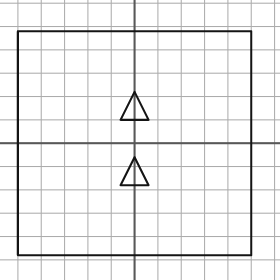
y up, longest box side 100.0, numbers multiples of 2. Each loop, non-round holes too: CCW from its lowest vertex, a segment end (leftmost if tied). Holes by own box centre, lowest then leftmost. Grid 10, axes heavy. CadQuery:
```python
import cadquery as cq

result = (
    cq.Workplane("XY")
    .moveTo(-50.0, -48.0)
    .lineTo(50.0, -48.0)
    .lineTo(50.0, 48.0)
    .lineTo(-50.0, 48.0)
    .close()
    .moveTo(-6.0, -18.0)
    .lineTo(6.0, -18.0)
    .lineTo(0.0, -6.0)
    .close()
    .moveTo(-6.0, 10.0)
    .lineTo(6.0, 10.0)
    .lineTo(0.0, 22.0)
    .close()
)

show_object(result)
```